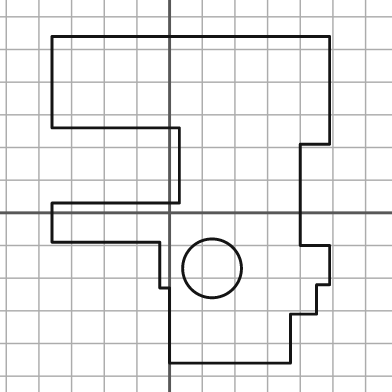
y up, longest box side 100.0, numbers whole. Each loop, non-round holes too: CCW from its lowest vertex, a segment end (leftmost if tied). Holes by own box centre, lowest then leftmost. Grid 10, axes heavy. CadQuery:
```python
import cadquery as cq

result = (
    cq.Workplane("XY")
    .moveTo(0.0, -46.0)
    .lineTo(37.0, -46.0)
    .lineTo(37.0, -31.0)
    .lineTo(45.0, -31.0)
    .lineTo(45.0, -22.0)
    .lineTo(49.0, -22.0)
    .lineTo(49.0, -10.0)
    .lineTo(40.0, -10.0)
    .lineTo(40.0, 21.0)
    .lineTo(49.0, 21.0)
    .lineTo(49.0, 54.0)
    .lineTo(-36.0, 54.0)
    .lineTo(-36.0, 26.0)
    .lineTo(3.0, 26.0)
    .lineTo(3.0, 3.0)
    .lineTo(-36.0, 3.0)
    .lineTo(-36.0, -9.0)
    .lineTo(-3.0, -9.0)
    .lineTo(-3.0, -23.0)
    .lineTo(0.0, -23.0)
    .close()
    .moveTo(13.0, -17.0)
    .circle(9.0)
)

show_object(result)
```